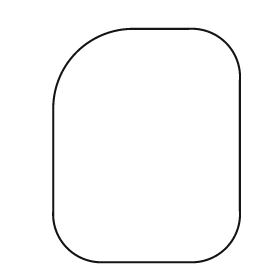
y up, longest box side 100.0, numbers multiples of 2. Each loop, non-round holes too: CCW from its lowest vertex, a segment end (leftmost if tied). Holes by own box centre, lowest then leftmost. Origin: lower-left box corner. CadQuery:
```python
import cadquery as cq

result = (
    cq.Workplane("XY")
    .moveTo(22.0, 0.0)
    .lineTo(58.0, 0.0)
    .threePointArc((74.0, 6.0), (80.0, 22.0))
    .lineTo(80.0, 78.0)
    .threePointArc((74.0, 94.0), (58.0, 100.0))
    .lineTo(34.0, 100.0)
    .threePointArc((10.0, 90.0), (0.0, 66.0))
    .lineTo(0.0, 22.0)
    .threePointArc((6.0, 6.0), (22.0, 0.0))
    .close()
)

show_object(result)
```